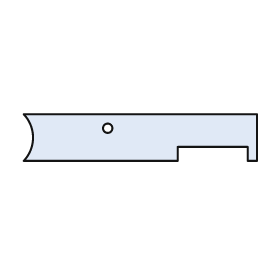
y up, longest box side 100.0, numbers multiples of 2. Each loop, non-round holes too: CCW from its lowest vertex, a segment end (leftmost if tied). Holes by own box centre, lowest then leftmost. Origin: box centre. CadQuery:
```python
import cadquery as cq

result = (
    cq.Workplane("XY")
    .moveTo(-50.0, -10.0)
    .lineTo(16.0, -10.0)
    .lineTo(16.0, -4.0)
    .lineTo(46.0, -4.0)
    .lineTo(46.0, -10.0)
    .lineTo(50.0, -10.0)
    .lineTo(50.0, 10.0)
    .lineTo(-50.0, 10.0)
    .threePointArc((-46.0, 0.0), (-50.0, -10.0))
    .close()
    .moveTo(-14.0, 4.0)
    .circle(2.0)
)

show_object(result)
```